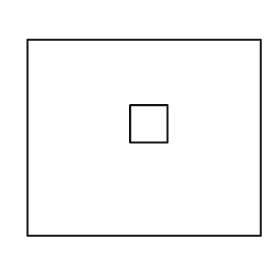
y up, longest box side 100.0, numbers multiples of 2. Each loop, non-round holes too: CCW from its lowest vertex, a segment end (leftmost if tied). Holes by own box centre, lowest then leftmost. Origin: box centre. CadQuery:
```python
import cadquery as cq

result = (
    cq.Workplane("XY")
    .moveTo(-50.0, -42.0)
    .lineTo(50.0, -42.0)
    .lineTo(50.0, 42.0)
    .lineTo(-50.0, 42.0)
    .close()
    .moveTo(-6.0, -2.0)
    .lineTo(10.0, -2.0)
    .lineTo(10.0, 14.0)
    .lineTo(-6.0, 14.0)
    .close()
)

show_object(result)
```